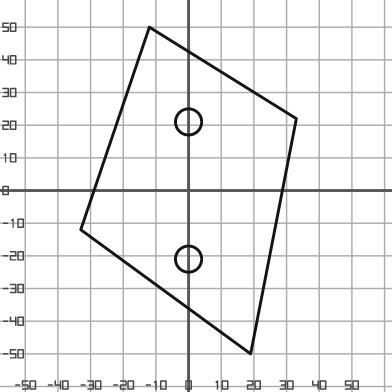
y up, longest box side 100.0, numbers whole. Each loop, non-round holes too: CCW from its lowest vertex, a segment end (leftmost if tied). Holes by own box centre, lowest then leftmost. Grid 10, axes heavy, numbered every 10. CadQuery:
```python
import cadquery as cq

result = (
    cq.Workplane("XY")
    .moveTo(19.0, -50.0)
    .lineTo(33.0, 22.0)
    .lineTo(-12.0, 50.0)
    .lineTo(-33.0, -12.0)
    .close()
    .moveTo(0.0, -21.0)
    .circle(4.0)
    .moveTo(0.0, 21.0)
    .circle(4.0)
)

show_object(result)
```